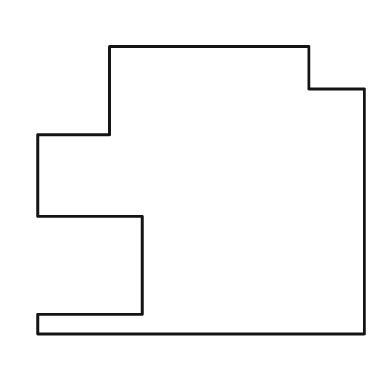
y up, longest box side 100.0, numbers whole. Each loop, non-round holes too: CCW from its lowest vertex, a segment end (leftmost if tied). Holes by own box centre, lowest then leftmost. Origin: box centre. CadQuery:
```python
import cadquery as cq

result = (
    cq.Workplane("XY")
    .moveTo(-50.0, -44.0)
    .lineTo(50.0, -44.0)
    .lineTo(50.0, 31.0)
    .lineTo(33.0, 31.0)
    .lineTo(33.0, 44.0)
    .lineTo(-28.0, 44.0)
    .lineTo(-28.0, 17.0)
    .lineTo(-50.0, 17.0)
    .lineTo(-50.0, -8.0)
    .lineTo(-18.0, -8.0)
    .lineTo(-18.0, -38.0)
    .lineTo(-50.0, -38.0)
    .close()
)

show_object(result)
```